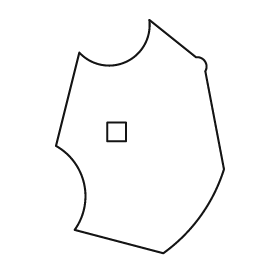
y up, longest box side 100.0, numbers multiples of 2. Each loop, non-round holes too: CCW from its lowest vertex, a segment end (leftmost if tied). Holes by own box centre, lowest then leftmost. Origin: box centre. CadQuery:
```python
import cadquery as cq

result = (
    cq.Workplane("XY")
    .moveTo(10.0, -50.0)
    .threePointArc((26.0, -34.0), (36.0, -14.0))
    .lineTo(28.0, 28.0)
    .threePointArc((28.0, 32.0), (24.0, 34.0))
    .lineTo(4.0, 50.0)
    .threePointArc((-6.0, 32.0), (-26.0, 36.0))
    .lineTo(-36.0, -4.0)
    .threePointArc((-24.0, -20.0), (-28.0, -40.0))
    .close()
    .moveTo(-14.0, -2.0)
    .lineTo(-6.0, -2.0)
    .lineTo(-6.0, 6.0)
    .lineTo(-14.0, 6.0)
    .close()
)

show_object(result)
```